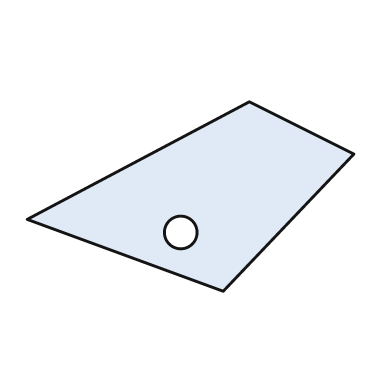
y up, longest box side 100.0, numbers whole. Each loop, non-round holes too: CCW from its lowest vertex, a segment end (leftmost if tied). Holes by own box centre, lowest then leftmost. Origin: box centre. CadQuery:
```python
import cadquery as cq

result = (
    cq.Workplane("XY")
    .moveTo(10.0, -29.0)
    .lineTo(50.0, 13.0)
    .lineTo(18.0, 29.0)
    .lineTo(-50.0, -7.0)
    .close()
    .moveTo(-3.0, -11.0)
    .circle(5.0)
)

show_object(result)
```